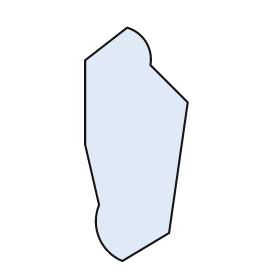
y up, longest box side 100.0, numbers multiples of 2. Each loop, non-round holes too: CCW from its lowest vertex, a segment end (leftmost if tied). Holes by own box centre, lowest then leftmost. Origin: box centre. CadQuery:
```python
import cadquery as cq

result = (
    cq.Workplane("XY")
    .moveTo(-6.0, -50.0)
    .lineTo(14.0, -38.0)
    .lineTo(22.0, 18.0)
    .lineTo(6.0, 34.0)
    .threePointArc((4.0, 44.0), (-4.0, 50.0))
    .lineTo(-22.0, 36.0)
    .lineTo(-22.0, 0.0)
    .lineTo(-16.0, -26.0)
    .threePointArc((-16.0, -40.0), (-6.0, -50.0))
    .close()
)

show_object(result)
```